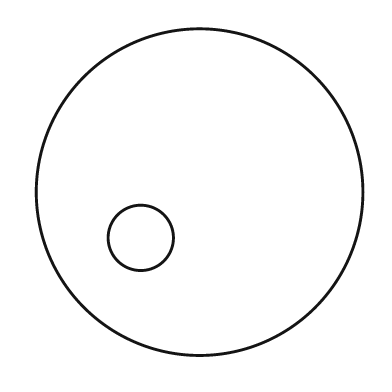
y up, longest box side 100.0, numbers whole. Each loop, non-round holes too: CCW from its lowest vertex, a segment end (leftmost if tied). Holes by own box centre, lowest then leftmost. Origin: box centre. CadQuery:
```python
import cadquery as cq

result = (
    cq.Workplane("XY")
    .moveTo(0.0, 0.0)
    .circle(50.0)
    .moveTo(-18.0, -14.0)
    .circle(10.0)
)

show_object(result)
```